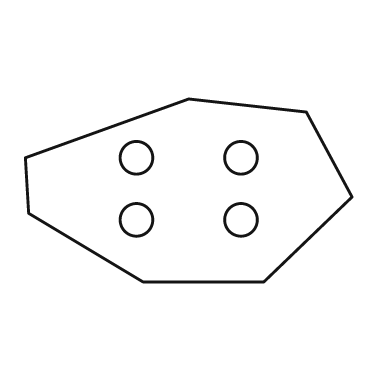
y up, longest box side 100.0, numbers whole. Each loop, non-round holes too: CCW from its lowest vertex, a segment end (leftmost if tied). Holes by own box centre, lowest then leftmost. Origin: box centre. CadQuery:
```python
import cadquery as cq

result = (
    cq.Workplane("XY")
    .moveTo(-14.0, -28.0)
    .lineTo(23.0, -28.0)
    .lineTo(50.0, -2.0)
    .lineTo(36.0, 24.0)
    .lineTo(0.0, 28.0)
    .lineTo(-50.0, 10.0)
    .lineTo(-49.0, -7.0)
    .close()
    .moveTo(-16.0, -9.0)
    .circle(5.0)
    .moveTo(16.0, -9.0)
    .circle(5.0)
    .moveTo(-16.0, 10.0)
    .circle(5.0)
    .moveTo(16.0, 10.0)
    .circle(5.0)
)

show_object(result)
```